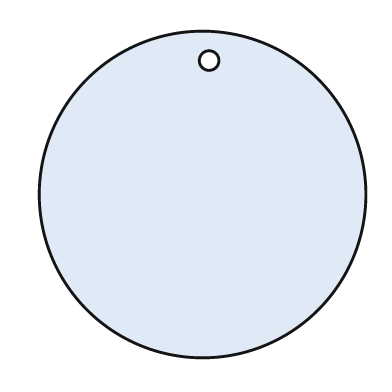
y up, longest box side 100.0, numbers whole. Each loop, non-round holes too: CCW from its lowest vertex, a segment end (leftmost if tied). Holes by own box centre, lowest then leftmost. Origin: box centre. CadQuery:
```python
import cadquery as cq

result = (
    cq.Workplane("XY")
    .moveTo(0.0, 0.0)
    .circle(50.0)
    .moveTo(2.0, 41.0)
    .circle(3.0)
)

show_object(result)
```